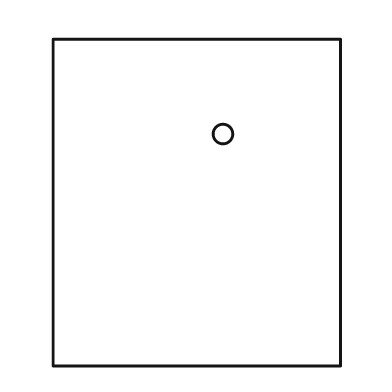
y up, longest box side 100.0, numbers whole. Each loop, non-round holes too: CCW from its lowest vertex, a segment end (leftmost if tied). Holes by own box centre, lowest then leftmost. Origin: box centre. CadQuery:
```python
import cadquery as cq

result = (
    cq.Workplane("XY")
    .moveTo(-44.0, -50.0)
    .lineTo(44.0, -50.0)
    .lineTo(44.0, 50.0)
    .lineTo(-44.0, 50.0)
    .close()
    .moveTo(8.0, 21.0)
    .circle(3.0)
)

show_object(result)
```